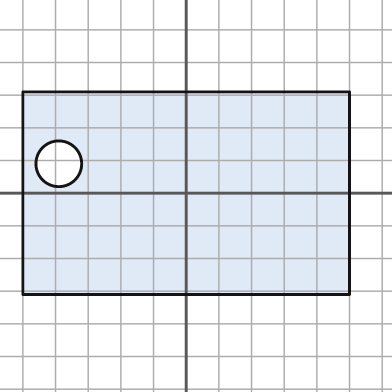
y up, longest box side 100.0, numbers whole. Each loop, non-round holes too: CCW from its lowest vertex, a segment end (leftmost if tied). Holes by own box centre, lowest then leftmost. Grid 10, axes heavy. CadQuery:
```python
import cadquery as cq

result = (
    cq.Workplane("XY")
    .moveTo(-50.0, -31.0)
    .lineTo(50.0, -31.0)
    .lineTo(50.0, 31.0)
    .lineTo(-50.0, 31.0)
    .close()
    .moveTo(-39.0, 9.0)
    .circle(7.0)
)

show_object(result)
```